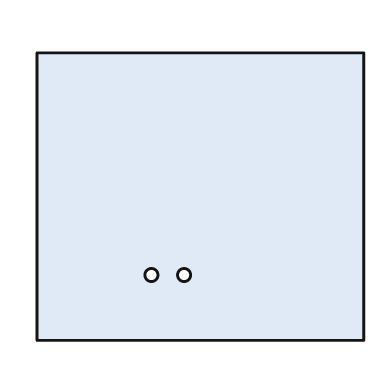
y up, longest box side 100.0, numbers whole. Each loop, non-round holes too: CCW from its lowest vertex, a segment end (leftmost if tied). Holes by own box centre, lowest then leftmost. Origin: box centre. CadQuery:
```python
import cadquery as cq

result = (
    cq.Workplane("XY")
    .moveTo(-50.0, -44.0)
    .lineTo(50.0, -44.0)
    .lineTo(50.0, 44.0)
    .lineTo(-50.0, 44.0)
    .close()
    .moveTo(-15.0, -24.0)
    .circle(2.0)
    .moveTo(-5.0, -24.0)
    .circle(2.0)
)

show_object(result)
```